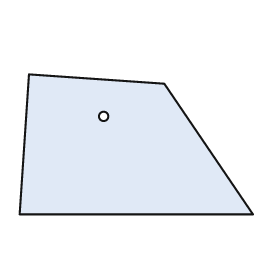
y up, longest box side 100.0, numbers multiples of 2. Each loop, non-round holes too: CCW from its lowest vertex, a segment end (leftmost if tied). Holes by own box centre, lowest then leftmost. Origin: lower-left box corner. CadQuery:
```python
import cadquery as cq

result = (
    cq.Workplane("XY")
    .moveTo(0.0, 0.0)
    .lineTo(100.0, 0.0)
    .lineTo(62.0, 56.0)
    .lineTo(4.0, 60.0)
    .close()
    .moveTo(36.0, 42.0)
    .circle(2.0)
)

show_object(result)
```